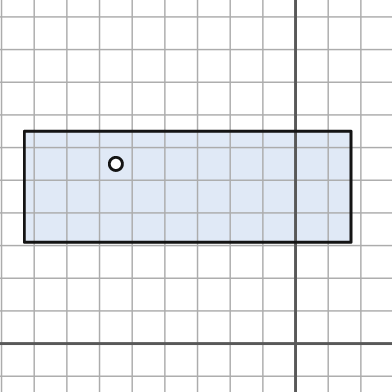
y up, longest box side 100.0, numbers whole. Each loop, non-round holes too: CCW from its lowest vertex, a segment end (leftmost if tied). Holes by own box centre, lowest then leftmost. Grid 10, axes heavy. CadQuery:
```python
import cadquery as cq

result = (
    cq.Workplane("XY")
    .moveTo(-83.0, 31.0)
    .lineTo(17.0, 31.0)
    .lineTo(17.0, 65.0)
    .lineTo(-83.0, 65.0)
    .close()
    .moveTo(-55.0, 55.0)
    .circle(2.0)
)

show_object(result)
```